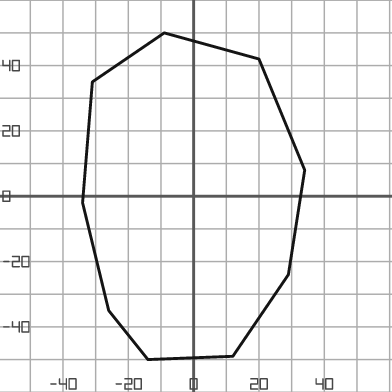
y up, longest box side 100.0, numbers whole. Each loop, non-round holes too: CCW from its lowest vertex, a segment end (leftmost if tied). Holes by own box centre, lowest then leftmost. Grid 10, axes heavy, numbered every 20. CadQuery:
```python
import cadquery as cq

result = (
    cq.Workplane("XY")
    .moveTo(-14.0, -50.0)
    .lineTo(12.0, -49.0)
    .lineTo(29.0, -24.0)
    .lineTo(34.0, 8.0)
    .lineTo(20.0, 42.0)
    .lineTo(-9.0, 50.0)
    .lineTo(-31.0, 35.0)
    .lineTo(-34.0, -2.0)
    .lineTo(-26.0, -35.0)
    .close()
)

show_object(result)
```